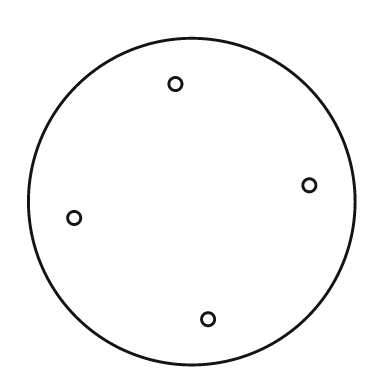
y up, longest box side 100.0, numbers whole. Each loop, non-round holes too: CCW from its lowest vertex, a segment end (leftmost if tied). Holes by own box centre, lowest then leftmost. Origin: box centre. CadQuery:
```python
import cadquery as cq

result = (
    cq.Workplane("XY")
    .moveTo(0.0, 0.0)
    .circle(50.0)
    .moveTo(5.0, -36.0)
    .circle(2.0)
    .moveTo(-36.0, -5.0)
    .circle(2.0)
    .moveTo(36.0, 5.0)
    .circle(2.0)
    .moveTo(-5.0, 36.0)
    .circle(2.0)
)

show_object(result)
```